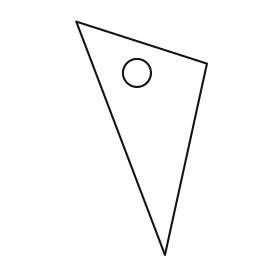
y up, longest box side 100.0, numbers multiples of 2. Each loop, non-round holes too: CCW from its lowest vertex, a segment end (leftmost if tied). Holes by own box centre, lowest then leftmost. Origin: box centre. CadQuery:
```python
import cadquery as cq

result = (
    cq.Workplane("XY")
    .moveTo(10.0, -50.0)
    .lineTo(28.0, 32.0)
    .lineTo(-28.0, 50.0)
    .close()
    .moveTo(-2.0, 28.0)
    .circle(6.0)
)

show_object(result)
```